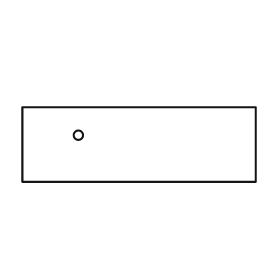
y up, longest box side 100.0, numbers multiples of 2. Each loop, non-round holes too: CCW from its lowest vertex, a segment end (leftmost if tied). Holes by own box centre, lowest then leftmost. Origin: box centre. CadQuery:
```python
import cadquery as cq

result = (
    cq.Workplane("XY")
    .moveTo(-50.0, -16.0)
    .lineTo(50.0, -16.0)
    .lineTo(50.0, 16.0)
    .lineTo(-50.0, 16.0)
    .close()
    .moveTo(-26.0, 4.0)
    .circle(2.0)
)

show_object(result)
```